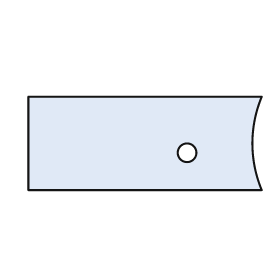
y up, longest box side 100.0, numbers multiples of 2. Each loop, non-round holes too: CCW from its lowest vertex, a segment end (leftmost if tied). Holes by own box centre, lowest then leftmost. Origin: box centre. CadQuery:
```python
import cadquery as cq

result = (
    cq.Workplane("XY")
    .moveTo(-50.0, -20.0)
    .lineTo(50.0, -20.0)
    .threePointArc((46.0, 0.0), (50.0, 20.0))
    .lineTo(-50.0, 20.0)
    .close()
    .moveTo(18.0, -4.0)
    .circle(4.0)
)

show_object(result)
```